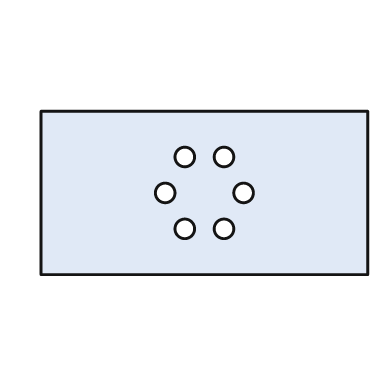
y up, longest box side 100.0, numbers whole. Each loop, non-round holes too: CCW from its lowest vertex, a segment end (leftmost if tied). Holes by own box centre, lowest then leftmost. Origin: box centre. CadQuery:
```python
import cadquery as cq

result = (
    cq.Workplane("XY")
    .moveTo(-50.0, -25.0)
    .lineTo(50.0, -25.0)
    .lineTo(50.0, 25.0)
    .lineTo(-50.0, 25.0)
    .close()
    .moveTo(-6.0, -11.0)
    .circle(3.0)
    .moveTo(6.0, -11.0)
    .circle(3.0)
    .moveTo(-12.0, 0.0)
    .circle(3.0)
    .moveTo(12.0, 0.0)
    .circle(3.0)
    .moveTo(-6.0, 11.0)
    .circle(3.0)
    .moveTo(6.0, 11.0)
    .circle(3.0)
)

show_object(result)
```